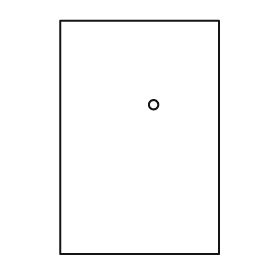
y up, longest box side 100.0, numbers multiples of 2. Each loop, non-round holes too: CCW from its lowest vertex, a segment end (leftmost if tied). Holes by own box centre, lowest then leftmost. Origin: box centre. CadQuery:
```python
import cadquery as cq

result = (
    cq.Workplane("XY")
    .moveTo(-34.0, -50.0)
    .lineTo(34.0, -50.0)
    .lineTo(34.0, 50.0)
    .lineTo(-34.0, 50.0)
    .close()
    .moveTo(6.0, 14.0)
    .circle(2.0)
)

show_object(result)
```